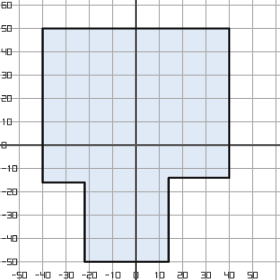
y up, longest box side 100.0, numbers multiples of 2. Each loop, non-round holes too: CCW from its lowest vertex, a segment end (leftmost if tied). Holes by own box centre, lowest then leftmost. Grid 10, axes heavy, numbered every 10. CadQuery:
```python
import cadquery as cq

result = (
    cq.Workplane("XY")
    .moveTo(-22.0, -50.0)
    .lineTo(14.0, -50.0)
    .lineTo(14.0, -14.0)
    .lineTo(40.0, -14.0)
    .lineTo(40.0, 50.0)
    .lineTo(-40.0, 50.0)
    .lineTo(-40.0, -16.0)
    .lineTo(-22.0, -16.0)
    .close()
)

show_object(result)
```